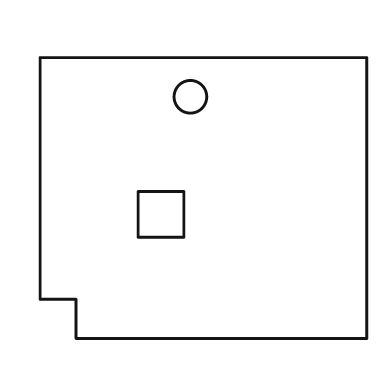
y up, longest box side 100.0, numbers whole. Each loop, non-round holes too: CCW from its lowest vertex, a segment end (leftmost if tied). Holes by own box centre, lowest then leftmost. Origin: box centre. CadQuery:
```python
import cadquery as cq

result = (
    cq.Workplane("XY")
    .moveTo(-39.0, -43.0)
    .lineTo(50.0, -43.0)
    .lineTo(50.0, 43.0)
    .lineTo(-50.0, 43.0)
    .lineTo(-50.0, -31.0)
    .lineTo(-39.0, -31.0)
    .close()
    .moveTo(-20.0, -12.0)
    .lineTo(-6.0, -12.0)
    .lineTo(-6.0, 2.0)
    .lineTo(-20.0, 2.0)
    .close()
    .moveTo(-4.0, 31.0)
    .circle(5.0)
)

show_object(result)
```